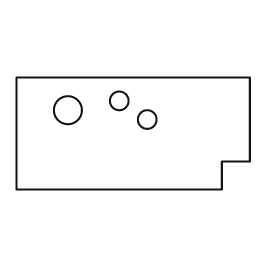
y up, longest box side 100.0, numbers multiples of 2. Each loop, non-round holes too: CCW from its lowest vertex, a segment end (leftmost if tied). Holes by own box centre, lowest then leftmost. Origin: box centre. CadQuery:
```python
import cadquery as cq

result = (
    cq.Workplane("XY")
    .moveTo(-50.0, -24.0)
    .lineTo(38.0, -24.0)
    .lineTo(38.0, -12.0)
    .lineTo(50.0, -12.0)
    .lineTo(50.0, 24.0)
    .lineTo(-50.0, 24.0)
    .close()
    .moveTo(6.0, 6.0)
    .circle(4.0)
    .moveTo(-28.0, 10.0)
    .circle(6.0)
    .moveTo(-6.0, 14.0)
    .circle(4.0)
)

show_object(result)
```